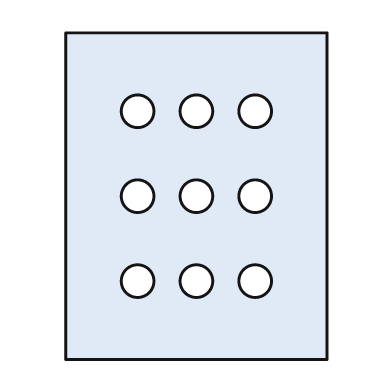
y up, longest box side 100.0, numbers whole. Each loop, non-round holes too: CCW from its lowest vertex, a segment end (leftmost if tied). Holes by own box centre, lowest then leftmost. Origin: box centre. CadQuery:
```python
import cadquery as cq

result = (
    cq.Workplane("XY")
    .moveTo(-40.0, -50.0)
    .lineTo(40.0, -50.0)
    .lineTo(40.0, 50.0)
    .lineTo(-40.0, 50.0)
    .close()
    .moveTo(-18.0, -26.0)
    .circle(5.0)
    .moveTo(0.0, -26.0)
    .circle(5.0)
    .moveTo(18.0, -26.0)
    .circle(5.0)
    .moveTo(-18.0, 0.0)
    .circle(5.0)
    .moveTo(0.0, 0.0)
    .circle(5.0)
    .moveTo(18.0, 0.0)
    .circle(5.0)
    .moveTo(-18.0, 26.0)
    .circle(5.0)
    .moveTo(0.0, 26.0)
    .circle(5.0)
    .moveTo(18.0, 26.0)
    .circle(5.0)
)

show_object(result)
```